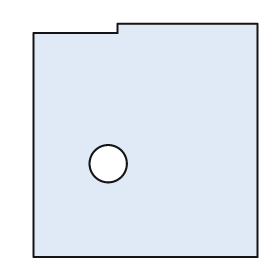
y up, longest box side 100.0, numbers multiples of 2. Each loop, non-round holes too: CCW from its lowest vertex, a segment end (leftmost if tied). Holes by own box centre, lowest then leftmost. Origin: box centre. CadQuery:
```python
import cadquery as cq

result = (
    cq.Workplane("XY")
    .moveTo(-48.0, -50.0)
    .lineTo(48.0, -50.0)
    .lineTo(48.0, 50.0)
    .lineTo(-12.0, 50.0)
    .lineTo(-12.0, 46.0)
    .lineTo(-48.0, 46.0)
    .close()
    .moveTo(-16.0, -10.0)
    .circle(8.0)
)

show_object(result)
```